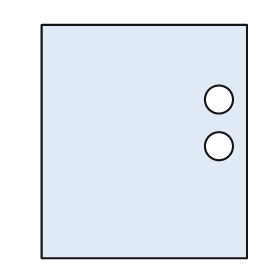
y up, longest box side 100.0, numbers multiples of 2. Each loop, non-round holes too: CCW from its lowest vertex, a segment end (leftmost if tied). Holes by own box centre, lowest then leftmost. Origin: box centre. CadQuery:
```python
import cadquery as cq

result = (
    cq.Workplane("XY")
    .moveTo(-44.0, -50.0)
    .lineTo(44.0, -50.0)
    .lineTo(44.0, 50.0)
    .lineTo(-44.0, 50.0)
    .close()
    .moveTo(32.0, -2.0)
    .circle(6.0)
    .moveTo(32.0, 18.0)
    .circle(6.0)
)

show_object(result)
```